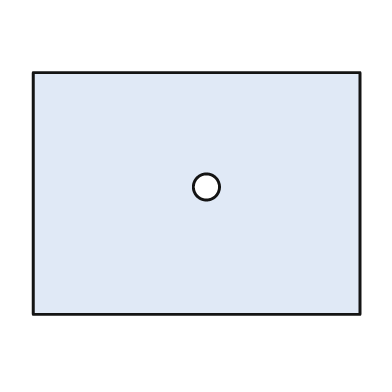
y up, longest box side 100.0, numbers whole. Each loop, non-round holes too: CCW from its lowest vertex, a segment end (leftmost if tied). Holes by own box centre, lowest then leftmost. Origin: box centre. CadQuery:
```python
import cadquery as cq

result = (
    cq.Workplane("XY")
    .moveTo(-50.0, -37.0)
    .lineTo(50.0, -37.0)
    .lineTo(50.0, 37.0)
    .lineTo(-50.0, 37.0)
    .close()
    .moveTo(3.0, 2.0)
    .circle(4.0)
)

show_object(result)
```